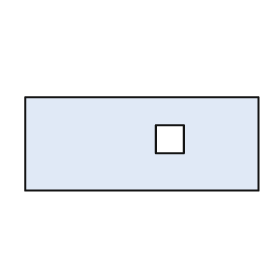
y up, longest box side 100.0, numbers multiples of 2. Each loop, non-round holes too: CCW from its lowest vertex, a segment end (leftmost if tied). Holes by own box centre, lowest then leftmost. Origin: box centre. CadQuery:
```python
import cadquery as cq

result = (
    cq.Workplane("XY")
    .moveTo(-50.0, -20.0)
    .lineTo(50.0, -20.0)
    .lineTo(50.0, 20.0)
    .lineTo(-50.0, 20.0)
    .close()
    .moveTo(6.0, -4.0)
    .lineTo(18.0, -4.0)
    .lineTo(18.0, 8.0)
    .lineTo(6.0, 8.0)
    .close()
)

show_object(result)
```